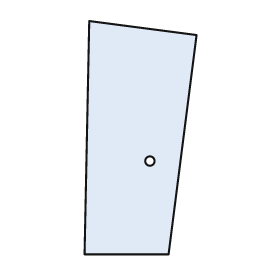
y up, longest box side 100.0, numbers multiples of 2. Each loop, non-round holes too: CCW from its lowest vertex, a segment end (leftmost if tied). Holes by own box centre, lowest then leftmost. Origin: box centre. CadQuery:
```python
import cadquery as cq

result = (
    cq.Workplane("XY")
    .moveTo(-24.0, -50.0)
    .lineTo(12.0, -50.0)
    .lineTo(24.0, 44.0)
    .lineTo(-22.0, 50.0)
    .close()
    .moveTo(4.0, -10.0)
    .circle(2.0)
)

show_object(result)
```